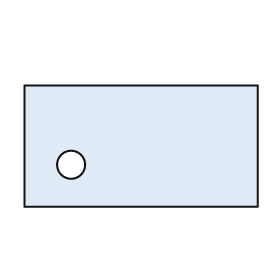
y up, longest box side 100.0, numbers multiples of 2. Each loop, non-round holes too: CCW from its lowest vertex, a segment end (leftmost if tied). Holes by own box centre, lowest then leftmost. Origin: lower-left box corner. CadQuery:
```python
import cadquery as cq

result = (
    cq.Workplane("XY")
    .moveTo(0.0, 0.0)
    .lineTo(100.0, 0.0)
    .lineTo(100.0, 52.0)
    .lineTo(0.0, 52.0)
    .close()
    .moveTo(20.0, 18.0)
    .circle(6.0)
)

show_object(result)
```